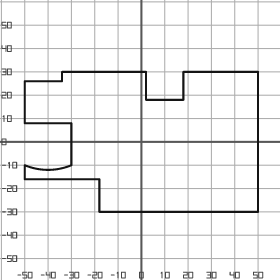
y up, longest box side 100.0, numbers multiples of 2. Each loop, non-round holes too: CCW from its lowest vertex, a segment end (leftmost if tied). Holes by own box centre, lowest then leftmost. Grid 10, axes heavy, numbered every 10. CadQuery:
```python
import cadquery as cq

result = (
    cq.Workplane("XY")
    .moveTo(-18.0, -30.0)
    .lineTo(50.0, -30.0)
    .lineTo(50.0, 30.0)
    .lineTo(18.0, 30.0)
    .lineTo(18.0, 18.0)
    .lineTo(2.0, 18.0)
    .lineTo(2.0, 30.0)
    .lineTo(-34.0, 30.0)
    .lineTo(-34.0, 26.0)
    .lineTo(-50.0, 26.0)
    .lineTo(-50.0, 8.0)
    .lineTo(-30.0, 8.0)
    .lineTo(-30.0, -10.0)
    .threePointArc((-40.0, -12.0), (-50.0, -10.0))
    .lineTo(-50.0, -16.0)
    .lineTo(-18.0, -16.0)
    .close()
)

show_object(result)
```